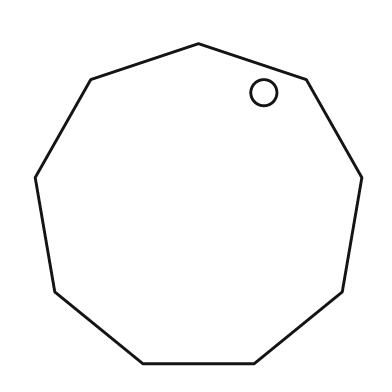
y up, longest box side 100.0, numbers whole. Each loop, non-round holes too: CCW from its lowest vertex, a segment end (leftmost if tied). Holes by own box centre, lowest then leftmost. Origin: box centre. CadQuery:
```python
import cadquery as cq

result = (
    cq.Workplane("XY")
    .moveTo(-17.0, -49.0)
    .lineTo(17.0, -49.0)
    .lineTo(44.0, -27.0)
    .lineTo(50.0, 8.0)
    .lineTo(33.0, 38.0)
    .lineTo(0.0, 49.0)
    .lineTo(-33.0, 38.0)
    .lineTo(-50.0, 8.0)
    .lineTo(-44.0, -27.0)
    .close()
    .moveTo(20.0, 34.0)
    .circle(4.0)
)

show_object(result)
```